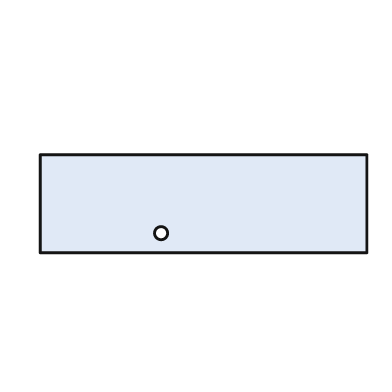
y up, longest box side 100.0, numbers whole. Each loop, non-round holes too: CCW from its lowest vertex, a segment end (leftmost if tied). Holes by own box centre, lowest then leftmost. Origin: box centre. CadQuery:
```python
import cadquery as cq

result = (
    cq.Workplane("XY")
    .moveTo(-50.0, -15.0)
    .lineTo(50.0, -15.0)
    .lineTo(50.0, 15.0)
    .lineTo(-50.0, 15.0)
    .close()
    .moveTo(-13.0, -9.0)
    .circle(2.0)
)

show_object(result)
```